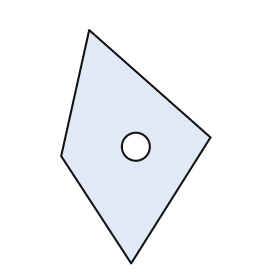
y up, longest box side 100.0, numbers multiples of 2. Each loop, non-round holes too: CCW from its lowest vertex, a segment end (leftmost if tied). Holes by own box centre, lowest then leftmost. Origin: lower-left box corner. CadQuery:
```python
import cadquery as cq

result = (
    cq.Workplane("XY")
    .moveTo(30.0, 0.0)
    .lineTo(64.0, 54.0)
    .lineTo(12.0, 100.0)
    .lineTo(0.0, 46.0)
    .close()
    .moveTo(32.0, 50.0)
    .circle(6.0)
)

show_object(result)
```